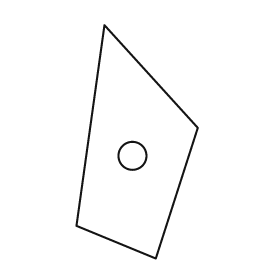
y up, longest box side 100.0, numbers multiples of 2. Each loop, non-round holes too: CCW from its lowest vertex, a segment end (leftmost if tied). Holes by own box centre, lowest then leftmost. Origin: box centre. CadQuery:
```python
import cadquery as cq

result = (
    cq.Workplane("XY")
    .moveTo(8.0, -50.0)
    .lineTo(26.0, 6.0)
    .lineTo(-14.0, 50.0)
    .lineTo(-26.0, -36.0)
    .close()
    .moveTo(-2.0, -6.0)
    .circle(6.0)
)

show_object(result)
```